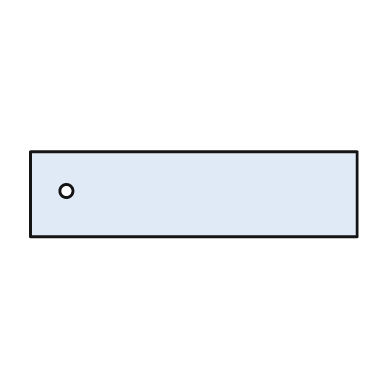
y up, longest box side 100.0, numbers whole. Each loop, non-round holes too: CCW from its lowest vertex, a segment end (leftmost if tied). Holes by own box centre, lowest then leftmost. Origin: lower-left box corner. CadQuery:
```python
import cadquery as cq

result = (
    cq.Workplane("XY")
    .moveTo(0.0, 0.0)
    .lineTo(100.0, 0.0)
    .lineTo(100.0, 26.0)
    .lineTo(0.0, 26.0)
    .close()
    .moveTo(11.0, 14.0)
    .circle(2.0)
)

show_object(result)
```